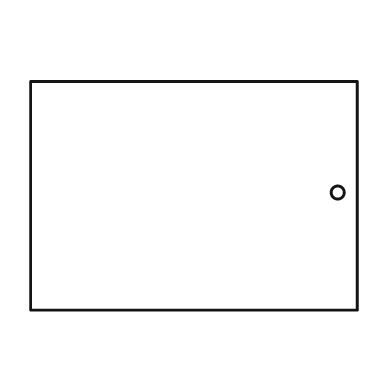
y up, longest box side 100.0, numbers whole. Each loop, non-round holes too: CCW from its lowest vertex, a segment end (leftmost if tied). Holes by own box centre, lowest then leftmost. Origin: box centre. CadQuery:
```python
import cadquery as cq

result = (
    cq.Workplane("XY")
    .moveTo(-50.0, -35.0)
    .lineTo(50.0, -35.0)
    .lineTo(50.0, 35.0)
    .lineTo(-50.0, 35.0)
    .close()
    .moveTo(44.0, 1.0)
    .circle(2.0)
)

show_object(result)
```